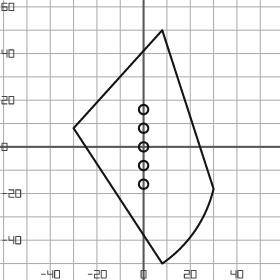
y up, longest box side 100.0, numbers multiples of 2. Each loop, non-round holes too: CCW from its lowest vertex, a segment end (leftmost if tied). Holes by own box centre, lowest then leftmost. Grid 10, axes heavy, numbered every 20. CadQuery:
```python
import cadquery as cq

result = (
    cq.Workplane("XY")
    .moveTo(8.0, -50.0)
    .threePointArc((22.0, -36.0), (30.0, -18.0))
    .lineTo(8.0, 50.0)
    .lineTo(-30.0, 8.0)
    .close()
    .moveTo(0.0, -16.0)
    .circle(2.0)
    .moveTo(0.0, -8.0)
    .circle(2.0)
    .moveTo(0.0, 0.0)
    .circle(2.0)
    .moveTo(0.0, 8.0)
    .circle(2.0)
    .moveTo(0.0, 16.0)
    .circle(2.0)
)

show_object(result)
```